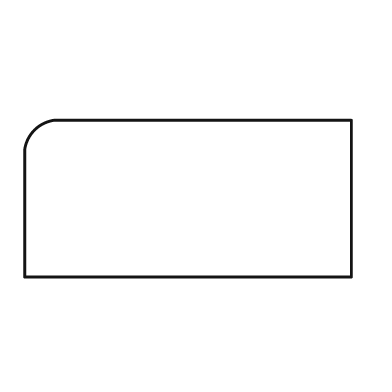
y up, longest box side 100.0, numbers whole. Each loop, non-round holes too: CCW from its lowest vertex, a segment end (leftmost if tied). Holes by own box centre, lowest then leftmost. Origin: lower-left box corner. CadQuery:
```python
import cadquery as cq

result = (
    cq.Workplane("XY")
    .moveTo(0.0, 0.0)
    .lineTo(100.0, 0.0)
    .lineTo(100.0, 48.0)
    .lineTo(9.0, 48.0)
    .threePointArc((3.0, 45.0), (0.0, 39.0))
    .close()
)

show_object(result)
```